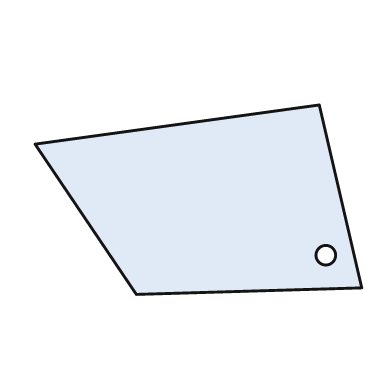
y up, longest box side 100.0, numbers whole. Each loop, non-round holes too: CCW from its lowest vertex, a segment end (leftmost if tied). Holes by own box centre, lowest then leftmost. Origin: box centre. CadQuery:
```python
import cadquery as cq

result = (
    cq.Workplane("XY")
    .moveTo(-19.0, -29.0)
    .lineTo(50.0, -27.0)
    .lineTo(37.0, 29.0)
    .lineTo(-50.0, 17.0)
    .close()
    .moveTo(39.0, -17.0)
    .circle(3.0)
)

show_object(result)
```